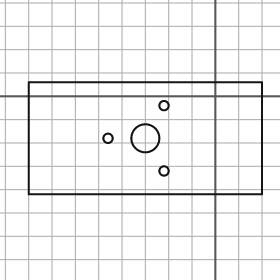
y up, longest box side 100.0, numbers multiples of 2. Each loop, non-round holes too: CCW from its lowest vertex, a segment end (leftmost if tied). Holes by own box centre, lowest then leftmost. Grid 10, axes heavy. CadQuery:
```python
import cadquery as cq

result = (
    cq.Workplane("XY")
    .moveTo(-80.0, -42.0)
    .lineTo(20.0, -42.0)
    .lineTo(20.0, 6.0)
    .lineTo(-80.0, 6.0)
    .close()
    .moveTo(-22.0, -32.0)
    .circle(2.0)
    .moveTo(-46.0, -18.0)
    .circle(2.0)
    .moveTo(-30.0, -18.0)
    .circle(6.0)
    .moveTo(-22.0, -4.0)
    .circle(2.0)
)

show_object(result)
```